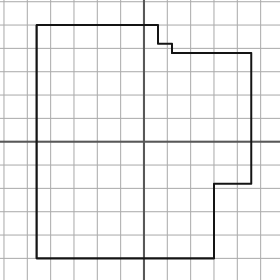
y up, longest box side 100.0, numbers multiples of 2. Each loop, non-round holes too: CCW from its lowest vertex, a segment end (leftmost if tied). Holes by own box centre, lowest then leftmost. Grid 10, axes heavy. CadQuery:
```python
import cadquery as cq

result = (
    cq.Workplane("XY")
    .moveTo(-46.0, -50.0)
    .lineTo(30.0, -50.0)
    .lineTo(30.0, -18.0)
    .lineTo(46.0, -18.0)
    .lineTo(46.0, 38.0)
    .lineTo(12.0, 38.0)
    .lineTo(12.0, 42.0)
    .lineTo(6.0, 42.0)
    .lineTo(6.0, 50.0)
    .lineTo(-46.0, 50.0)
    .close()
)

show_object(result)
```